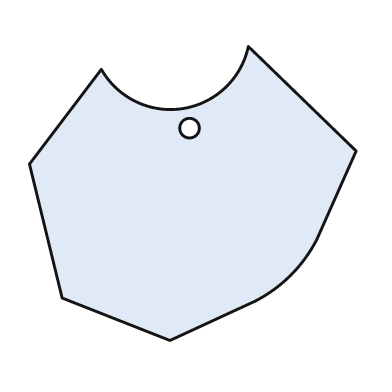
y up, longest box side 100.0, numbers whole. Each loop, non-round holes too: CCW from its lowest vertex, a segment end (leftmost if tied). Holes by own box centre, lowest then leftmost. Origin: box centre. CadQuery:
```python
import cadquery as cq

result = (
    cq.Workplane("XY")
    .moveTo(-7.0, -45.0)
    .lineTo(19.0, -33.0)
    .threePointArc((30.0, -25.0), (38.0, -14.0))
    .lineTo(50.0, 13.0)
    .lineTo(17.0, 45.0)
    .threePointArc((-3.0, 26.0), (-28.0, 38.0))
    .lineTo(-50.0, 9.0)
    .lineTo(-40.0, -32.0)
    .close()
    .moveTo(-1.0, 20.0)
    .circle(3.0)
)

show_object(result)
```